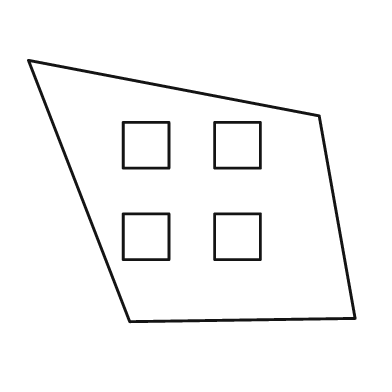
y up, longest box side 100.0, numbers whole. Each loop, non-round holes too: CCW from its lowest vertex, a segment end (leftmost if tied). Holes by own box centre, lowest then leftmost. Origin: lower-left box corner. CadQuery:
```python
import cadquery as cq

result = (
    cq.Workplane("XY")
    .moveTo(31.0, 0.0)
    .lineTo(100.0, 1.0)
    .lineTo(89.0, 63.0)
    .lineTo(0.0, 80.0)
    .close()
    .moveTo(29.0, 19.0)
    .lineTo(43.0, 19.0)
    .lineTo(43.0, 33.0)
    .lineTo(29.0, 33.0)
    .close()
    .moveTo(57.0, 19.0)
    .lineTo(71.0, 19.0)
    .lineTo(71.0, 33.0)
    .lineTo(57.0, 33.0)
    .close()
    .moveTo(29.0, 47.0)
    .lineTo(43.0, 47.0)
    .lineTo(43.0, 61.0)
    .lineTo(29.0, 61.0)
    .close()
    .moveTo(57.0, 47.0)
    .lineTo(71.0, 47.0)
    .lineTo(71.0, 61.0)
    .lineTo(57.0, 61.0)
    .close()
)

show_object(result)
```